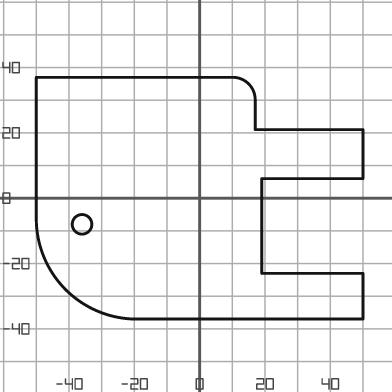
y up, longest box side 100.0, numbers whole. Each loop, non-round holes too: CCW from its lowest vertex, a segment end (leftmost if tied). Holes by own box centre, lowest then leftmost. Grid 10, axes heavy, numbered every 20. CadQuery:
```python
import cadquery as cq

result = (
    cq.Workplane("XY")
    .moveTo(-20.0, -37.0)
    .lineTo(50.0, -37.0)
    .lineTo(50.0, -23.0)
    .lineTo(19.0, -23.0)
    .lineTo(19.0, 6.0)
    .lineTo(50.0, 6.0)
    .lineTo(50.0, 21.0)
    .lineTo(17.0, 21.0)
    .lineTo(17.0, 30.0)
    .threePointArc((15.0, 35.0), (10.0, 37.0))
    .lineTo(-50.0, 37.0)
    .lineTo(-50.0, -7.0)
    .threePointArc((-41.0, -28.0), (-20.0, -37.0))
    .close()
    .moveTo(-36.0, -8.0)
    .circle(3.0)
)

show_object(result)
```